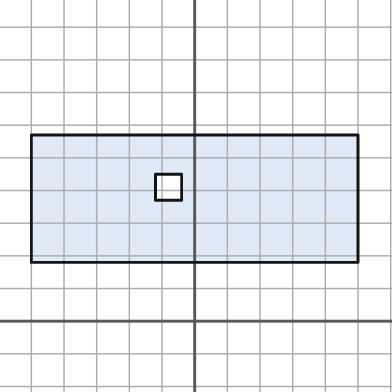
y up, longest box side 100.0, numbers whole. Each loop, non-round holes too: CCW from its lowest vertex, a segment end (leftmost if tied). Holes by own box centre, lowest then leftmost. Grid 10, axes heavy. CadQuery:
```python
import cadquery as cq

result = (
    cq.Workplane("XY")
    .moveTo(-50.0, 18.0)
    .lineTo(50.0, 18.0)
    .lineTo(50.0, 57.0)
    .lineTo(-50.0, 57.0)
    .close()
    .moveTo(-12.0, 37.0)
    .lineTo(-4.0, 37.0)
    .lineTo(-4.0, 45.0)
    .lineTo(-12.0, 45.0)
    .close()
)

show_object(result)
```